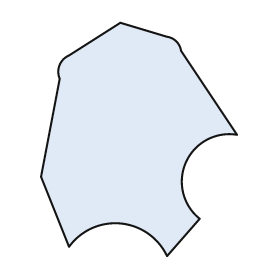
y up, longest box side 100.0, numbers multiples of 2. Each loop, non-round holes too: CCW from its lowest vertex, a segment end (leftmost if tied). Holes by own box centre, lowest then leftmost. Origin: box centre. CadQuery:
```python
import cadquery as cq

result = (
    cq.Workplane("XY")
    .moveTo(12.0, -50.0)
    .lineTo(26.0, -34.0)
    .threePointArc((20.0, -10.0), (42.0, 2.0))
    .lineTo(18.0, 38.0)
    .threePointArc((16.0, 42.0), (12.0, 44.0))
    .lineTo(-8.0, 50.0)
    .lineTo(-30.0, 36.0)
    .threePointArc((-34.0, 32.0), (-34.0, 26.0))
    .lineTo(-42.0, -16.0)
    .lineTo(-30.0, -46.0)
    .threePointArc((-8.0, -36.0), (12.0, -50.0))
    .close()
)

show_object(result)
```